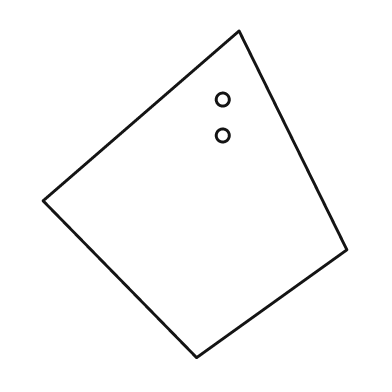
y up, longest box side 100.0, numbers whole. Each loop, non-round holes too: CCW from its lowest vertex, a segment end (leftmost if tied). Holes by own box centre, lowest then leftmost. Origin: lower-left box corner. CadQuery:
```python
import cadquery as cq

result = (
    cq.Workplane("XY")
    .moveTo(47.0, 0.0)
    .lineTo(93.0, 33.0)
    .lineTo(60.0, 100.0)
    .lineTo(0.0, 48.0)
    .close()
    .moveTo(55.0, 68.0)
    .circle(2.0)
    .moveTo(55.0, 79.0)
    .circle(2.0)
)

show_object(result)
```